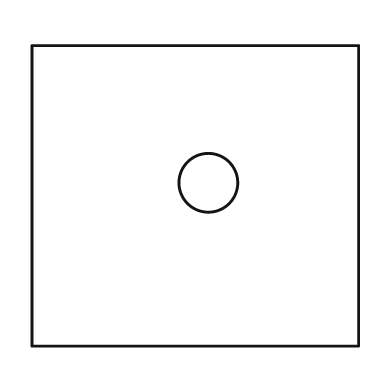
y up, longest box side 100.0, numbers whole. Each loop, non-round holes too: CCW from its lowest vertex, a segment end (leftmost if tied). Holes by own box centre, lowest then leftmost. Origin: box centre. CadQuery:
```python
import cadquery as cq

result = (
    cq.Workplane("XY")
    .moveTo(-50.0, -46.0)
    .lineTo(50.0, -46.0)
    .lineTo(50.0, 46.0)
    .lineTo(-50.0, 46.0)
    .close()
    .moveTo(4.0, 4.0)
    .circle(9.0)
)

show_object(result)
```